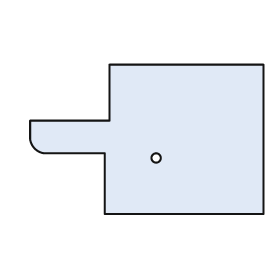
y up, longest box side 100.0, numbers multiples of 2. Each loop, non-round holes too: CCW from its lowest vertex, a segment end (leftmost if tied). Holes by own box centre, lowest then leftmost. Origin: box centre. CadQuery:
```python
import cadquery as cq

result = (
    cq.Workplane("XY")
    .moveTo(-18.0, -32.0)
    .lineTo(50.0, -32.0)
    .lineTo(50.0, 32.0)
    .lineTo(-16.0, 32.0)
    .lineTo(-16.0, 8.0)
    .lineTo(-50.0, 8.0)
    .lineTo(-50.0, 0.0)
    .threePointArc((-48.0, -4.0), (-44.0, -6.0))
    .lineTo(-18.0, -6.0)
    .close()
    .moveTo(4.0, -8.0)
    .circle(2.0)
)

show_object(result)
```